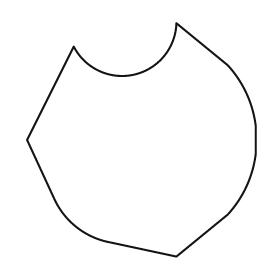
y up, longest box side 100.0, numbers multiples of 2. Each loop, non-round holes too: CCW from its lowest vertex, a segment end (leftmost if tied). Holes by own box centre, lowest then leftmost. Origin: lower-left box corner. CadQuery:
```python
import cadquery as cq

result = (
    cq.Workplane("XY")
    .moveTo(64.0, 0.0)
    .lineTo(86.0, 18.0)
    .threePointArc((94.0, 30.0), (98.0, 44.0))
    .lineTo(98.0, 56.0)
    .threePointArc((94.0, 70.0), (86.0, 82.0))
    .lineTo(64.0, 100.0)
    .threePointArc((46.0, 78.0), (20.0, 90.0))
    .lineTo(0.0, 50.0)
    .lineTo(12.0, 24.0)
    .threePointArc((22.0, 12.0), (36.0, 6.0))
    .close()
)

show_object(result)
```